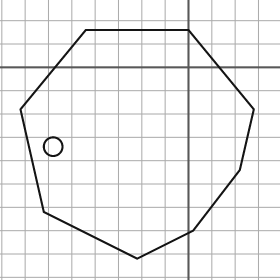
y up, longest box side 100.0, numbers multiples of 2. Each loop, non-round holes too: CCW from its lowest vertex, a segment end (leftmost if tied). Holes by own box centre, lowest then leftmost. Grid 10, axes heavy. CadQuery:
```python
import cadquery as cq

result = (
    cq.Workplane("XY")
    .moveTo(-22.0, -82.0)
    .lineTo(2.0, -70.0)
    .lineTo(22.0, -44.0)
    .lineTo(28.0, -18.0)
    .lineTo(0.0, 16.0)
    .lineTo(-44.0, 16.0)
    .lineTo(-72.0, -18.0)
    .lineTo(-62.0, -62.0)
    .close()
    .moveTo(-58.0, -34.0)
    .circle(4.0)
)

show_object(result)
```